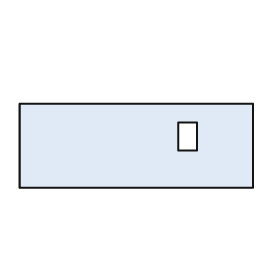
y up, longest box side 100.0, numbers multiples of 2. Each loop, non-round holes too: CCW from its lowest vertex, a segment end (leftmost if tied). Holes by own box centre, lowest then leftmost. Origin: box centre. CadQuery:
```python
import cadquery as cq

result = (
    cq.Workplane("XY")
    .moveTo(-50.0, -18.0)
    .lineTo(50.0, -18.0)
    .lineTo(50.0, 18.0)
    .lineTo(-50.0, 18.0)
    .close()
    .moveTo(18.0, -2.0)
    .lineTo(26.0, -2.0)
    .lineTo(26.0, 10.0)
    .lineTo(18.0, 10.0)
    .close()
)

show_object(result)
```